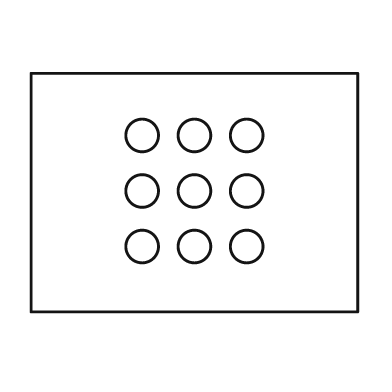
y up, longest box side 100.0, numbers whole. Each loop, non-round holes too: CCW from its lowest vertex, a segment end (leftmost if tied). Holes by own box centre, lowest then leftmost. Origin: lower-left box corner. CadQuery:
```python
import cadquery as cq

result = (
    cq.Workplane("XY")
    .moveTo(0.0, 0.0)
    .lineTo(100.0, 0.0)
    .lineTo(100.0, 73.0)
    .lineTo(0.0, 73.0)
    .close()
    .moveTo(34.0, 20.0)
    .circle(5.0)
    .moveTo(50.0, 20.0)
    .circle(5.0)
    .moveTo(66.0, 20.0)
    .circle(5.0)
    .moveTo(34.0, 37.0)
    .circle(5.0)
    .moveTo(50.0, 37.0)
    .circle(5.0)
    .moveTo(66.0, 37.0)
    .circle(5.0)
    .moveTo(34.0, 54.0)
    .circle(5.0)
    .moveTo(50.0, 54.0)
    .circle(5.0)
    .moveTo(66.0, 54.0)
    .circle(5.0)
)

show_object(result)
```